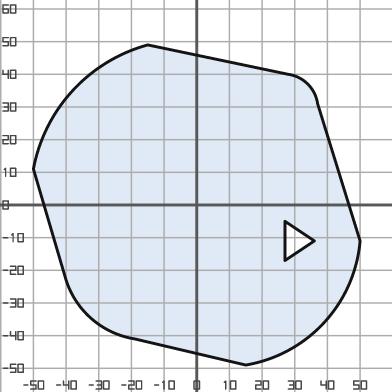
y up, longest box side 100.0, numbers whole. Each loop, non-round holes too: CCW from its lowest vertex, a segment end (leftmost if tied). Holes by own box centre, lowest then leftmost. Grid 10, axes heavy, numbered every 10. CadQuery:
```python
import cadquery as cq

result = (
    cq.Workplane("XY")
    .moveTo(15.0, -49.0)
    .threePointArc((39.0, -36.0), (50.0, -11.0))
    .lineTo(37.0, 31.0)
    .threePointArc((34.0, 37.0), (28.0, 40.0))
    .lineTo(-15.0, 49.0)
    .threePointArc((-38.0, 35.0), (-50.0, 11.0))
    .lineTo(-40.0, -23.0)
    .threePointArc((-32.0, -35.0), (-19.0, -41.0))
    .close()
    .moveTo(27.0, -17.0)
    .lineTo(36.0, -11.0)
    .lineTo(27.0, -5.0)
    .close()
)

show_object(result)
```